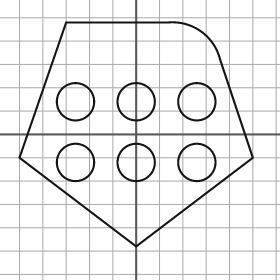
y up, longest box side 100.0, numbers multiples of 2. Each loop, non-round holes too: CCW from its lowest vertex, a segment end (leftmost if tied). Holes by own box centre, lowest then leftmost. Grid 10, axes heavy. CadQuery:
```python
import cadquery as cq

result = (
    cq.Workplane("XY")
    .moveTo(0.0, -48.0)
    .lineTo(50.0, -10.0)
    .lineTo(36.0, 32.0)
    .threePointArc((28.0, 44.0), (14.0, 48.0))
    .lineTo(-30.0, 48.0)
    .lineTo(-50.0, -10.0)
    .close()
    .moveTo(-26.0, -12.0)
    .circle(8.0)
    .moveTo(0.0, -12.0)
    .circle(8.0)
    .moveTo(26.0, -12.0)
    .circle(8.0)
    .moveTo(-26.0, 14.0)
    .circle(8.0)
    .moveTo(0.0, 14.0)
    .circle(8.0)
    .moveTo(26.0, 14.0)
    .circle(8.0)
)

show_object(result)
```